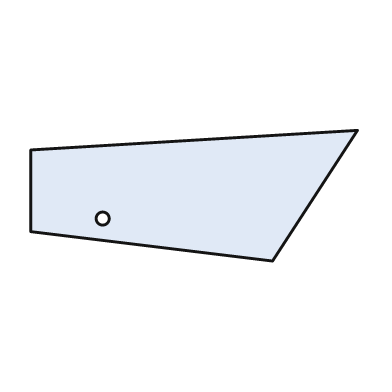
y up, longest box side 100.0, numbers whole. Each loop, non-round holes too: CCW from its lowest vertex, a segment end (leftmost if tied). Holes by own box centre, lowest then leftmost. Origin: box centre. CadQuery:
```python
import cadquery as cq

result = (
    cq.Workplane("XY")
    .moveTo(24.0, -20.0)
    .lineTo(50.0, 20.0)
    .lineTo(-50.0, 14.0)
    .lineTo(-50.0, -11.0)
    .close()
    .moveTo(-28.0, -7.0)
    .circle(2.0)
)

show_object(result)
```